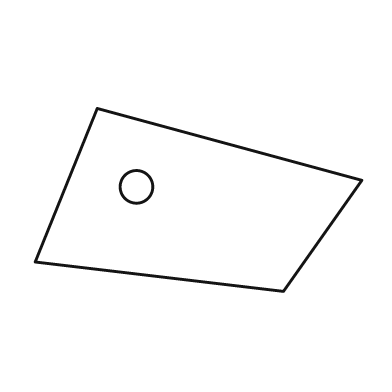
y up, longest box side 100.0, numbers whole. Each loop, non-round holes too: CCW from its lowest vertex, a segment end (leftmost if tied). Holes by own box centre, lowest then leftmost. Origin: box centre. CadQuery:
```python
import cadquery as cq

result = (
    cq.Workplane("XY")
    .moveTo(26.0, -28.0)
    .lineTo(50.0, 6.0)
    .lineTo(-31.0, 28.0)
    .lineTo(-50.0, -19.0)
    .close()
    .moveTo(-19.0, 4.0)
    .circle(5.0)
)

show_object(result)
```